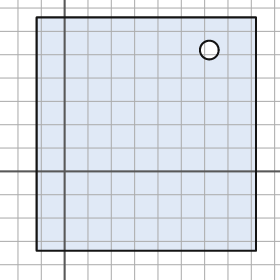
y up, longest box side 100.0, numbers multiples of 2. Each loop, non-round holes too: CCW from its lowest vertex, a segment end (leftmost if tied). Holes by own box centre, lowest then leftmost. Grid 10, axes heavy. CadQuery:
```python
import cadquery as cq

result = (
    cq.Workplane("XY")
    .moveTo(-12.0, -34.0)
    .lineTo(82.0, -34.0)
    .lineTo(82.0, 66.0)
    .lineTo(-12.0, 66.0)
    .close()
    .moveTo(62.0, 52.0)
    .circle(4.0)
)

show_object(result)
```